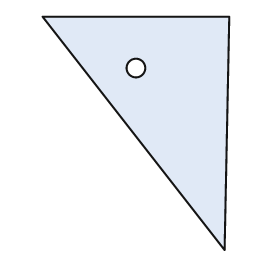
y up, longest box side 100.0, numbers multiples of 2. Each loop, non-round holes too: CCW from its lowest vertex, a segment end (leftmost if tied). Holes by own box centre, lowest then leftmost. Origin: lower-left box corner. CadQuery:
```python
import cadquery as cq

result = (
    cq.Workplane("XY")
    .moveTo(78.0, 0.0)
    .lineTo(80.0, 100.0)
    .lineTo(0.0, 100.0)
    .close()
    .moveTo(40.0, 78.0)
    .circle(4.0)
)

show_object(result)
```